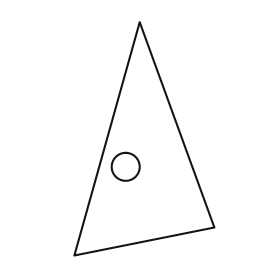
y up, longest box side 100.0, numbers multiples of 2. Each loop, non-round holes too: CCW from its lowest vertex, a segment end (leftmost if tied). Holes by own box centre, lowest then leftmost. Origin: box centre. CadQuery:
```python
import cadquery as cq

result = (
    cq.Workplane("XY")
    .moveTo(-30.0, -50.0)
    .lineTo(30.0, -38.0)
    .lineTo(-2.0, 50.0)
    .close()
    .moveTo(-8.0, -12.0)
    .circle(6.0)
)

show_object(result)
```